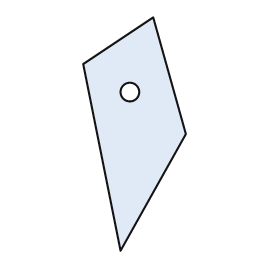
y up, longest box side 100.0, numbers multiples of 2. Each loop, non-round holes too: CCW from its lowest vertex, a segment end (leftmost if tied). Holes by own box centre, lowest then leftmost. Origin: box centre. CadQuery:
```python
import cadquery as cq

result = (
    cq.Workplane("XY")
    .moveTo(-6.0, -50.0)
    .lineTo(22.0, 0.0)
    .lineTo(8.0, 50.0)
    .lineTo(-22.0, 30.0)
    .close()
    .moveTo(-2.0, 18.0)
    .circle(4.0)
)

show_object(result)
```